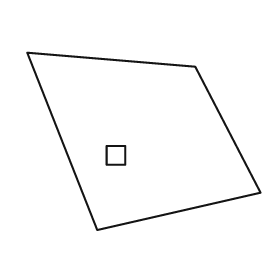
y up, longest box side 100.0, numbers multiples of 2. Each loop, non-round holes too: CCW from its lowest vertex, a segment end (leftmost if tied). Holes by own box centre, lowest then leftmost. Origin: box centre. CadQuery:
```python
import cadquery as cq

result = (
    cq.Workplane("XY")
    .moveTo(-20.0, -38.0)
    .lineTo(50.0, -22.0)
    .lineTo(22.0, 32.0)
    .lineTo(-50.0, 38.0)
    .close()
    .moveTo(-16.0, -10.0)
    .lineTo(-8.0, -10.0)
    .lineTo(-8.0, -2.0)
    .lineTo(-16.0, -2.0)
    .close()
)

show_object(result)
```